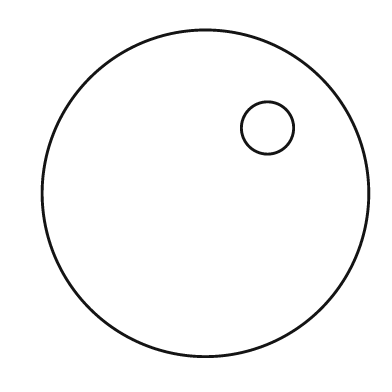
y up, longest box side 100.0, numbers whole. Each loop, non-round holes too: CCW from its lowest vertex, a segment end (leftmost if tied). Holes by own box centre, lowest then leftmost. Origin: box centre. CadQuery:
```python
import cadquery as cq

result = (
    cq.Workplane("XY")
    .moveTo(0.0, 0.0)
    .circle(50.0)
    .moveTo(19.0, 20.0)
    .circle(8.0)
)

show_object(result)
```